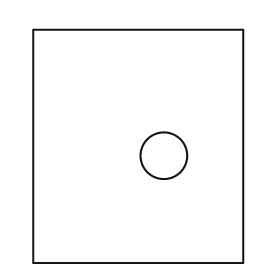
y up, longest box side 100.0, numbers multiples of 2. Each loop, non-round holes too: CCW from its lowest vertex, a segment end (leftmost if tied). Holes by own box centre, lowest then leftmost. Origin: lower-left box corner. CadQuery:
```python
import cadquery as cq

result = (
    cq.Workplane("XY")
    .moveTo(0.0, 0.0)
    .lineTo(90.0, 0.0)
    .lineTo(90.0, 100.0)
    .lineTo(0.0, 100.0)
    .close()
    .moveTo(56.0, 46.0)
    .circle(10.0)
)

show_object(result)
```